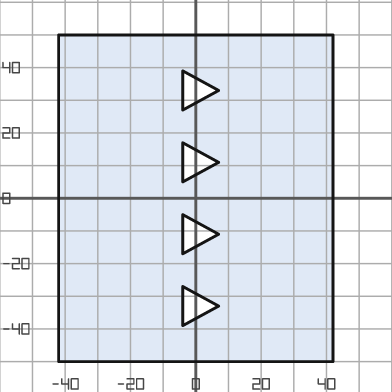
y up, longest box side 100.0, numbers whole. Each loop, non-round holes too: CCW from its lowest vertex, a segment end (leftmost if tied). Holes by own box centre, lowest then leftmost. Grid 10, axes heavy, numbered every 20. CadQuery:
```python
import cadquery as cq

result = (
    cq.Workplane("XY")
    .moveTo(-42.0, -50.0)
    .lineTo(42.0, -50.0)
    .lineTo(42.0, 50.0)
    .lineTo(-42.0, 50.0)
    .close()
    .moveTo(-4.0, -39.0)
    .lineTo(7.0, -33.0)
    .lineTo(-4.0, -27.0)
    .close()
    .moveTo(-4.0, -17.0)
    .lineTo(7.0, -11.0)
    .lineTo(-4.0, -5.0)
    .close()
    .moveTo(-4.0, 5.0)
    .lineTo(7.0, 11.0)
    .lineTo(-4.0, 17.0)
    .close()
    .moveTo(-4.0, 27.0)
    .lineTo(7.0, 33.0)
    .lineTo(-4.0, 39.0)
    .close()
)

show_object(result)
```